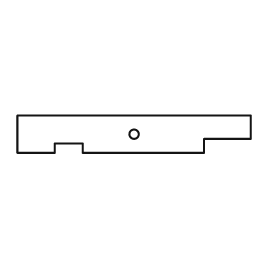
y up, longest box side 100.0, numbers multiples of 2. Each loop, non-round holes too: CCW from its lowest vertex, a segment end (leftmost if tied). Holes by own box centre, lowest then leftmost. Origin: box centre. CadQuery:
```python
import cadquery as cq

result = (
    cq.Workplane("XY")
    .moveTo(-50.0, -8.0)
    .lineTo(-34.0, -8.0)
    .lineTo(-34.0, -4.0)
    .lineTo(-22.0, -4.0)
    .lineTo(-22.0, -8.0)
    .lineTo(30.0, -8.0)
    .lineTo(30.0, -2.0)
    .lineTo(50.0, -2.0)
    .lineTo(50.0, 8.0)
    .lineTo(-50.0, 8.0)
    .close()
    .moveTo(0.0, 0.0)
    .circle(2.0)
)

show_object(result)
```